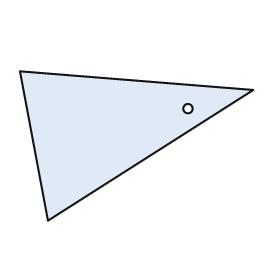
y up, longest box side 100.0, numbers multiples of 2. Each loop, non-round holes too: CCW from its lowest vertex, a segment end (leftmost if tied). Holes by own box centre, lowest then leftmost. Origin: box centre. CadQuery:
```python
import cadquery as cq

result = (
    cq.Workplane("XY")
    .moveTo(-38.0, -32.0)
    .lineTo(50.0, 24.0)
    .lineTo(-50.0, 32.0)
    .close()
    .moveTo(22.0, 16.0)
    .circle(2.0)
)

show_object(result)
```